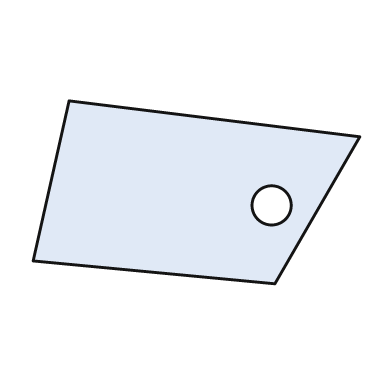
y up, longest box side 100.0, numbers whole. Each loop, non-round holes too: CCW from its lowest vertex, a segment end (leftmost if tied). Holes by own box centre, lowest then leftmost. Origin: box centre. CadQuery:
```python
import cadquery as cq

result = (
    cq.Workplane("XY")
    .moveTo(24.0, -28.0)
    .lineTo(50.0, 17.0)
    .lineTo(-39.0, 28.0)
    .lineTo(-50.0, -21.0)
    .close()
    .moveTo(23.0, -4.0)
    .circle(6.0)
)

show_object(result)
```